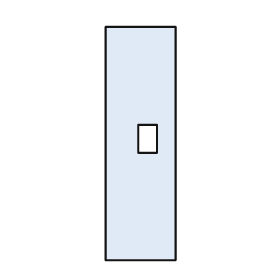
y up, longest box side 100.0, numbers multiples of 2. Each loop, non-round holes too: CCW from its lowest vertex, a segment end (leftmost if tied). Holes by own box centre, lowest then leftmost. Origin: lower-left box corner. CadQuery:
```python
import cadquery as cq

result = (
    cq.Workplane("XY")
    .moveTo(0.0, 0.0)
    .lineTo(30.0, 0.0)
    .lineTo(30.0, 100.0)
    .lineTo(0.0, 100.0)
    .close()
    .moveTo(14.0, 46.0)
    .lineTo(22.0, 46.0)
    .lineTo(22.0, 58.0)
    .lineTo(14.0, 58.0)
    .close()
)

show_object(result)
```